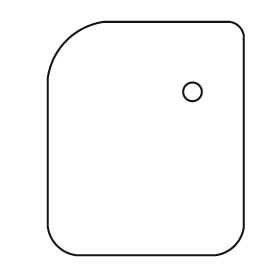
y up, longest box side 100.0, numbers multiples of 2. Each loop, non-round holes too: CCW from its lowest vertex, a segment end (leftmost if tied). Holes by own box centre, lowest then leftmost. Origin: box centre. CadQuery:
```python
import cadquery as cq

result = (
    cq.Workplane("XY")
    .moveTo(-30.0, -50.0)
    .lineTo(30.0, -50.0)
    .threePointArc((38.0, -46.0), (42.0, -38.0))
    .lineTo(42.0, 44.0)
    .threePointArc((40.0, 48.0), (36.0, 50.0))
    .lineTo(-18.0, 50.0)
    .threePointArc((-34.0, 42.0), (-42.0, 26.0))
    .lineTo(-42.0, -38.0)
    .threePointArc((-38.0, -46.0), (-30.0, -50.0))
    .close()
    .moveTo(20.0, 20.0)
    .circle(4.0)
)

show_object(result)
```